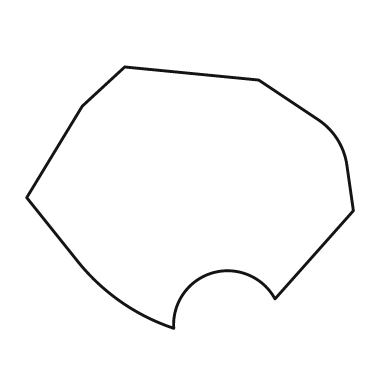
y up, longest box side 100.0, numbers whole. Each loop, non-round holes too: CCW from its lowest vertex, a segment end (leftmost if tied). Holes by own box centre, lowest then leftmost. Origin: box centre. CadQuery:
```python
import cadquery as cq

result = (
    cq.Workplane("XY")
    .moveTo(-5.0, -40.0)
    .threePointArc((7.0, -23.0), (26.0, -31.0))
    .lineTo(50.0, -4.0)
    .lineTo(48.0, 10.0)
    .threePointArc((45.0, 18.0), (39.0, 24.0))
    .lineTo(21.0, 36.0)
    .lineTo(-20.0, 40.0)
    .lineTo(-33.0, 28.0)
    .lineTo(-50.0, 0.0)
    .lineTo(-34.0, -20.0)
    .threePointArc((-21.0, -32.0), (-5.0, -40.0))
    .close()
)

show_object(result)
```